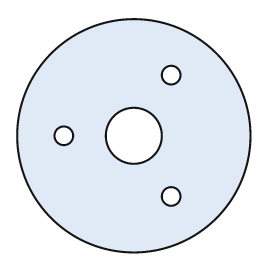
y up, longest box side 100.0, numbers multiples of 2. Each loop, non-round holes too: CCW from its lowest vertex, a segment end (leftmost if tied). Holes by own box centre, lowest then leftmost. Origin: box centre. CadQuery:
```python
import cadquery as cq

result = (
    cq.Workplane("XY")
    .moveTo(0.0, 0.0)
    .circle(50.0)
    .moveTo(16.0, -26.0)
    .circle(4.0)
    .moveTo(-30.0, 0.0)
    .circle(4.0)
    .moveTo(0.0, 0.0)
    .circle(12.0)
    .moveTo(16.0, 26.0)
    .circle(4.0)
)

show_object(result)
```